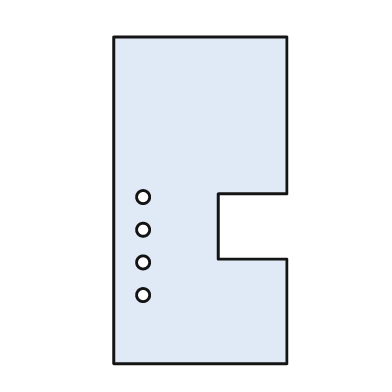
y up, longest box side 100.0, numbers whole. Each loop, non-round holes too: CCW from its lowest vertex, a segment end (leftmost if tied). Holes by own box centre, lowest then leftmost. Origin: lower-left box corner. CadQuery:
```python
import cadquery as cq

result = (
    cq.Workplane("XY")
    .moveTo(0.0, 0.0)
    .lineTo(53.0, 0.0)
    .lineTo(53.0, 32.0)
    .lineTo(32.0, 32.0)
    .lineTo(32.0, 52.0)
    .lineTo(53.0, 52.0)
    .lineTo(53.0, 100.0)
    .lineTo(0.0, 100.0)
    .close()
    .moveTo(9.0, 21.0)
    .circle(2.0)
    .moveTo(9.0, 31.0)
    .circle(2.0)
    .moveTo(9.0, 41.0)
    .circle(2.0)
    .moveTo(9.0, 51.0)
    .circle(2.0)
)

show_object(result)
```